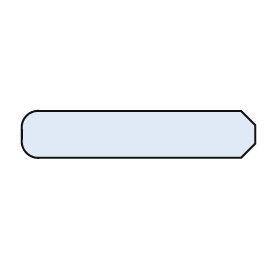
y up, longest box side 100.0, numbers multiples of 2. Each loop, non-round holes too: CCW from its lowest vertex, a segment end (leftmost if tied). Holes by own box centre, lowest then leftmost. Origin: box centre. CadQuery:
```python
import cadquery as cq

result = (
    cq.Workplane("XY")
    .moveTo(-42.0, -10.0)
    .lineTo(44.0, -10.0)
    .lineTo(50.0, -4.0)
    .lineTo(50.0, 4.0)
    .lineTo(44.0, 10.0)
    .lineTo(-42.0, 10.0)
    .threePointArc((-48.0, 8.0), (-50.0, 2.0))
    .lineTo(-50.0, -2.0)
    .threePointArc((-48.0, -8.0), (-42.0, -10.0))
    .close()
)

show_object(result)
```